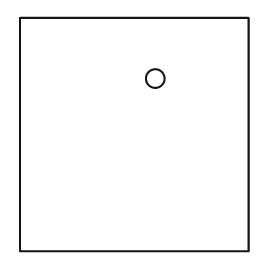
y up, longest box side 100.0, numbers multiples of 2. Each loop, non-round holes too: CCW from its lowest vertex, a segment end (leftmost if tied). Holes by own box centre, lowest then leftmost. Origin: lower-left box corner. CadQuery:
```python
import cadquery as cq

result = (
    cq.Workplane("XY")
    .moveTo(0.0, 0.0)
    .lineTo(98.0, 0.0)
    .lineTo(98.0, 100.0)
    .lineTo(0.0, 100.0)
    .close()
    .moveTo(58.0, 74.0)
    .circle(4.0)
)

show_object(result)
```